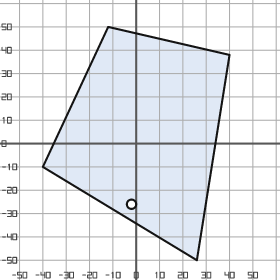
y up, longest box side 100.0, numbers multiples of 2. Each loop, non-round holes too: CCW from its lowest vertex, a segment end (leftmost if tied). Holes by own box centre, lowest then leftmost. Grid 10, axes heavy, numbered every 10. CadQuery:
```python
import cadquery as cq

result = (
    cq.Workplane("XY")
    .moveTo(26.0, -50.0)
    .lineTo(40.0, 38.0)
    .lineTo(-12.0, 50.0)
    .lineTo(-40.0, -10.0)
    .close()
    .moveTo(-2.0, -26.0)
    .circle(2.0)
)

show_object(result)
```